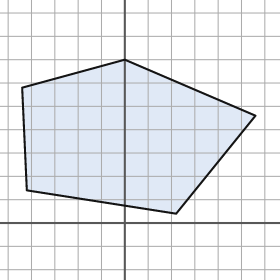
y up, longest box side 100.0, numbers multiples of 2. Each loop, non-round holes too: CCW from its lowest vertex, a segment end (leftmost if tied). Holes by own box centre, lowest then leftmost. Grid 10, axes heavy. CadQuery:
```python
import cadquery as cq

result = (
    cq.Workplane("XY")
    .moveTo(22.0, 4.0)
    .lineTo(56.0, 46.0)
    .lineTo(0.0, 70.0)
    .lineTo(-44.0, 58.0)
    .lineTo(-42.0, 14.0)
    .close()
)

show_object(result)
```